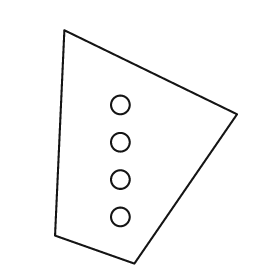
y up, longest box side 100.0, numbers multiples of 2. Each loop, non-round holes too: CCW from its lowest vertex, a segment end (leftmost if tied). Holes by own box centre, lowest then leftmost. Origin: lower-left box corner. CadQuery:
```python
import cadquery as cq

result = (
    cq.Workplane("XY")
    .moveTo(34.0, 0.0)
    .lineTo(78.0, 64.0)
    .lineTo(4.0, 100.0)
    .lineTo(0.0, 12.0)
    .close()
    .moveTo(28.0, 20.0)
    .circle(4.0)
    .moveTo(28.0, 36.0)
    .circle(4.0)
    .moveTo(28.0, 52.0)
    .circle(4.0)
    .moveTo(28.0, 68.0)
    .circle(4.0)
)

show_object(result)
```